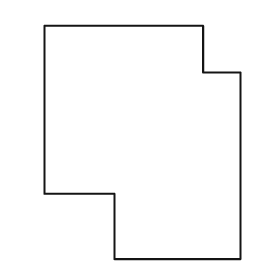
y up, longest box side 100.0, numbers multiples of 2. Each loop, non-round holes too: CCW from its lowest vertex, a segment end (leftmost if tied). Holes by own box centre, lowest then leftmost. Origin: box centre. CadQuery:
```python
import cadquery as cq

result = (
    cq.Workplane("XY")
    .moveTo(-12.0, -50.0)
    .lineTo(42.0, -50.0)
    .lineTo(42.0, 30.0)
    .lineTo(26.0, 30.0)
    .lineTo(26.0, 50.0)
    .lineTo(-42.0, 50.0)
    .lineTo(-42.0, -22.0)
    .lineTo(-12.0, -22.0)
    .close()
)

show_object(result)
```